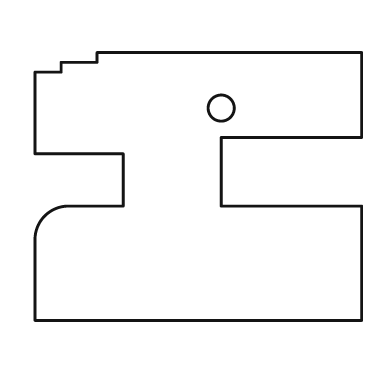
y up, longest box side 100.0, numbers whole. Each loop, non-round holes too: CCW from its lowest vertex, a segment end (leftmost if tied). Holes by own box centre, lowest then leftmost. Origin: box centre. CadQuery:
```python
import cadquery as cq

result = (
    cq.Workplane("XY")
    .moveTo(-50.0, -41.0)
    .lineTo(50.0, -41.0)
    .lineTo(50.0, -6.0)
    .lineTo(7.0, -6.0)
    .lineTo(7.0, 15.0)
    .lineTo(50.0, 15.0)
    .lineTo(50.0, 41.0)
    .lineTo(-31.0, 41.0)
    .lineTo(-31.0, 38.0)
    .lineTo(-42.0, 38.0)
    .lineTo(-42.0, 35.0)
    .lineTo(-50.0, 35.0)
    .lineTo(-50.0, 10.0)
    .lineTo(-23.0, 10.0)
    .lineTo(-23.0, -6.0)
    .lineTo(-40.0, -6.0)
    .threePointArc((-47.0, -9.0), (-50.0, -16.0))
    .close()
    .moveTo(7.0, 24.0)
    .circle(4.0)
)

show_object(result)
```